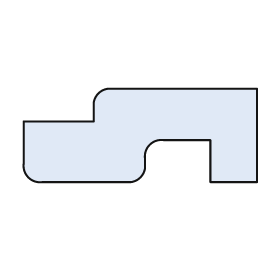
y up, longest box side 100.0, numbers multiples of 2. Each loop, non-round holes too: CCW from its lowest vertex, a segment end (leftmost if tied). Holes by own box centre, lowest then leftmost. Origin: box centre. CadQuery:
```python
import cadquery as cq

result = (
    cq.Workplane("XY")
    .moveTo(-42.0, -20.0)
    .lineTo(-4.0, -20.0)
    .threePointArc((0.0, -18.0), (2.0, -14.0))
    .lineTo(2.0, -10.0)
    .threePointArc((4.0, -4.0), (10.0, -2.0))
    .lineTo(30.0, -2.0)
    .lineTo(30.0, -20.0)
    .lineTo(50.0, -20.0)
    .lineTo(50.0, 20.0)
    .lineTo(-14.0, 20.0)
    .threePointArc((-18.0, 18.0), (-20.0, 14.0))
    .lineTo(-20.0, 6.0)
    .lineTo(-50.0, 6.0)
    .lineTo(-50.0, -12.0)
    .threePointArc((-48.0, -18.0), (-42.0, -20.0))
    .close()
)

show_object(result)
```